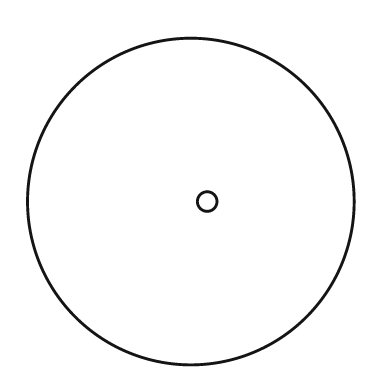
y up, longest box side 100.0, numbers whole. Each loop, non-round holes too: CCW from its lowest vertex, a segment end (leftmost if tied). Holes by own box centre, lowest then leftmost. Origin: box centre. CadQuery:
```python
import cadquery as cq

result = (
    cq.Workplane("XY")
    .moveTo(0.0, 0.0)
    .circle(50.0)
    .moveTo(5.0, 0.0)
    .circle(3.0)
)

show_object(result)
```